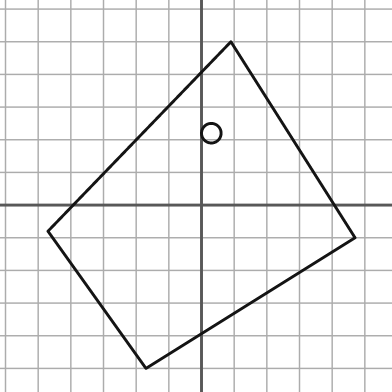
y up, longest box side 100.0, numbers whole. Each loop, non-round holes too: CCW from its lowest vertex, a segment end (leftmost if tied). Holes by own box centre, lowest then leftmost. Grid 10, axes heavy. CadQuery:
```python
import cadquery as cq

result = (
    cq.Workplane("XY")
    .moveTo(-17.0, -50.0)
    .lineTo(47.0, -10.0)
    .lineTo(9.0, 50.0)
    .lineTo(-47.0, -8.0)
    .close()
    .moveTo(3.0, 22.0)
    .circle(3.0)
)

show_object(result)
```